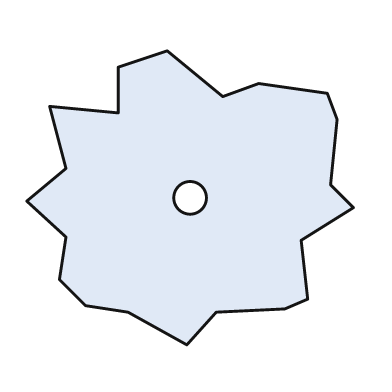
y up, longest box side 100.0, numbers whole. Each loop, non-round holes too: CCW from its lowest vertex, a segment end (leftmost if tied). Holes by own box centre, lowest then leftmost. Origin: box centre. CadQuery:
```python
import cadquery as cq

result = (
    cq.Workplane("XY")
    .moveTo(-1.0, -45.0)
    .lineTo(8.0, -35.0)
    .lineTo(29.0, -34.0)
    .lineTo(36.0, -31.0)
    .lineTo(34.0, -13.0)
    .lineTo(50.0, -3.0)
    .lineTo(43.0, 4.0)
    .lineTo(45.0, 24.0)
    .lineTo(42.0, 32.0)
    .lineTo(21.0, 35.0)
    .lineTo(10.0, 31.0)
    .lineTo(-7.0, 45.0)
    .lineTo(-22.0, 40.0)
    .lineTo(-22.0, 26.0)
    .lineTo(-43.0, 28.0)
    .lineTo(-38.0, 9.0)
    .lineTo(-50.0, -1.0)
    .lineTo(-38.0, -12.0)
    .lineTo(-40.0, -25.0)
    .lineTo(-32.0, -33.0)
    .lineTo(-19.0, -35.0)
    .close()
    .moveTo(0.0, 0.0)
    .circle(5.0)
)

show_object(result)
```